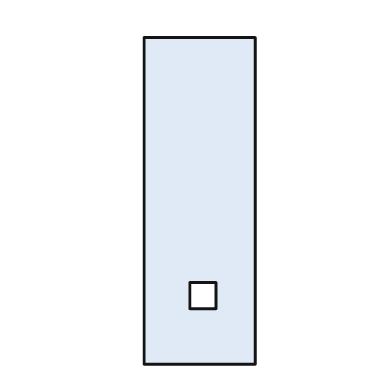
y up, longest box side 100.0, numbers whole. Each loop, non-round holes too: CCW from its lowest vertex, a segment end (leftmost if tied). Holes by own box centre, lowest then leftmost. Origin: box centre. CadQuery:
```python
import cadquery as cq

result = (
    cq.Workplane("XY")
    .moveTo(-17.0, -50.0)
    .lineTo(17.0, -50.0)
    .lineTo(17.0, 50.0)
    .lineTo(-17.0, 50.0)
    .close()
    .moveTo(-3.0, -33.0)
    .lineTo(5.0, -33.0)
    .lineTo(5.0, -25.0)
    .lineTo(-3.0, -25.0)
    .close()
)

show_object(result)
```